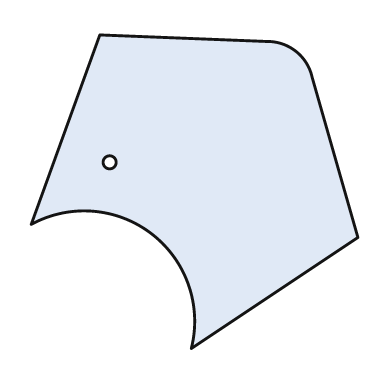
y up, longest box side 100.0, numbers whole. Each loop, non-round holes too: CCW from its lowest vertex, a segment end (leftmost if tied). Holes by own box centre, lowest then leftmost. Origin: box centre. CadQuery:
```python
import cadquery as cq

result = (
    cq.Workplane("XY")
    .moveTo(-1.0, -48.0)
    .lineTo(50.0, -14.0)
    .lineTo(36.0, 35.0)
    .threePointArc((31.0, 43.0), (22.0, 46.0))
    .lineTo(-29.0, 48.0)
    .lineTo(-50.0, -10.0)
    .threePointArc((-13.0, -13.0), (-1.0, -48.0))
    .close()
    .moveTo(-26.0, 9.0)
    .circle(2.0)
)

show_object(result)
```